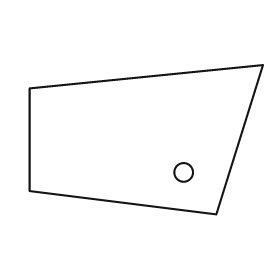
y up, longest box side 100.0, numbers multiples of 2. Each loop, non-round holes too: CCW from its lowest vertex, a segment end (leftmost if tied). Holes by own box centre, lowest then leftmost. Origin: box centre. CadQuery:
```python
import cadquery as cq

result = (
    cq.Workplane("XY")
    .moveTo(30.0, -32.0)
    .lineTo(50.0, 32.0)
    .lineTo(-50.0, 22.0)
    .lineTo(-50.0, -22.0)
    .close()
    .moveTo(16.0, -14.0)
    .circle(4.0)
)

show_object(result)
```